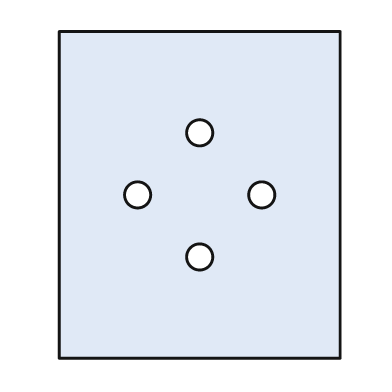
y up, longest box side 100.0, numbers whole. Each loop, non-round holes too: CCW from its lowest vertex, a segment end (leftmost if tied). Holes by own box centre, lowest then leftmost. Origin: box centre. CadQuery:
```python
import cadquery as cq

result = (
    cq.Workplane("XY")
    .moveTo(-43.0, -50.0)
    .lineTo(43.0, -50.0)
    .lineTo(43.0, 50.0)
    .lineTo(-43.0, 50.0)
    .close()
    .moveTo(0.0, -19.0)
    .circle(4.0)
    .moveTo(-19.0, 0.0)
    .circle(4.0)
    .moveTo(19.0, 0.0)
    .circle(4.0)
    .moveTo(0.0, 19.0)
    .circle(4.0)
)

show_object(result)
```